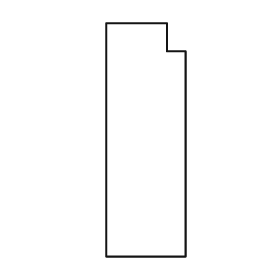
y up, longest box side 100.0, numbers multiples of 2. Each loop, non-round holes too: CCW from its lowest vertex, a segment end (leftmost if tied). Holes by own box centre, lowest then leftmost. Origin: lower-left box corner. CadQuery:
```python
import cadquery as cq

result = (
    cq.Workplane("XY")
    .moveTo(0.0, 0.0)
    .lineTo(34.0, 0.0)
    .lineTo(34.0, 88.0)
    .lineTo(26.0, 88.0)
    .lineTo(26.0, 100.0)
    .lineTo(0.0, 100.0)
    .close()
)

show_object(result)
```